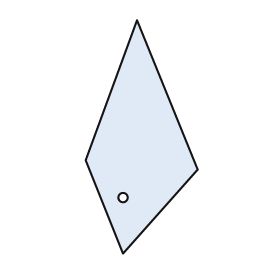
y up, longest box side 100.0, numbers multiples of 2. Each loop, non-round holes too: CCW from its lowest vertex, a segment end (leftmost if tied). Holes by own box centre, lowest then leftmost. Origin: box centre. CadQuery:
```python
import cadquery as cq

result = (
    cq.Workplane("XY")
    .moveTo(-8.0, -50.0)
    .lineTo(24.0, -14.0)
    .lineTo(-2.0, 50.0)
    .lineTo(-24.0, -10.0)
    .close()
    .moveTo(-8.0, -26.0)
    .circle(2.0)
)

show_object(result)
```